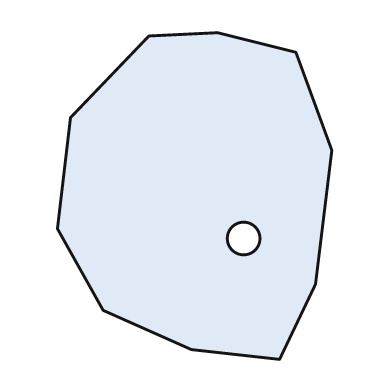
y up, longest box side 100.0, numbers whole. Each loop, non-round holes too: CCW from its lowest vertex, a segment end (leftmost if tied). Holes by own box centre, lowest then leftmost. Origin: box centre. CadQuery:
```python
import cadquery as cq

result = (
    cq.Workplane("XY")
    .moveTo(26.0, -50.0)
    .lineTo(37.0, -27.0)
    .lineTo(42.0, 14.0)
    .lineTo(31.0, 44.0)
    .lineTo(7.0, 50.0)
    .lineTo(-14.0, 49.0)
    .lineTo(-38.0, 24.0)
    .lineTo(-42.0, -10.0)
    .lineTo(-28.0, -35.0)
    .lineTo(-1.0, -47.0)
    .close()
    .moveTo(15.0, -13.0)
    .circle(5.0)
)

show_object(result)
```